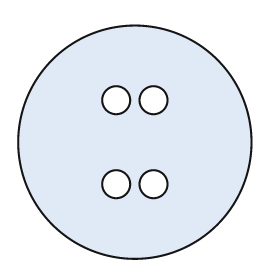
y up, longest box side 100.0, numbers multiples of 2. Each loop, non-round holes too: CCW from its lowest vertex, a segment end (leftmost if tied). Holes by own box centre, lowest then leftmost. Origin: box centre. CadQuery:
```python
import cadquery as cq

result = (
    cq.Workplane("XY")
    .moveTo(0.0, 0.0)
    .circle(50.0)
    .moveTo(-8.0, -18.0)
    .circle(6.0)
    .moveTo(8.0, -18.0)
    .circle(6.0)
    .moveTo(-8.0, 18.0)
    .circle(6.0)
    .moveTo(8.0, 18.0)
    .circle(6.0)
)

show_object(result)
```